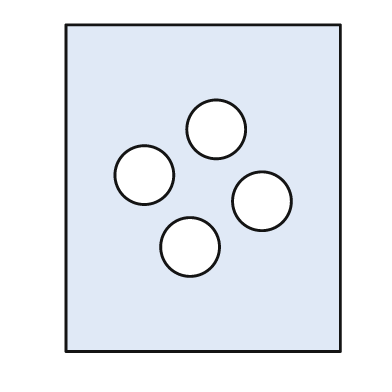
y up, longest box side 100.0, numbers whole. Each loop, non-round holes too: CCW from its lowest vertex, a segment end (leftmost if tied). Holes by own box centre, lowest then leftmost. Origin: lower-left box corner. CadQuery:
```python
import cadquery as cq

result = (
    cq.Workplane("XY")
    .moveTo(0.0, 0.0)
    .lineTo(84.0, 0.0)
    .lineTo(84.0, 100.0)
    .lineTo(0.0, 100.0)
    .close()
    .moveTo(38.0, 32.0)
    .circle(9.0)
    .moveTo(60.0, 46.0)
    .circle(9.0)
    .moveTo(24.0, 54.0)
    .circle(9.0)
    .moveTo(46.0, 68.0)
    .circle(9.0)
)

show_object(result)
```